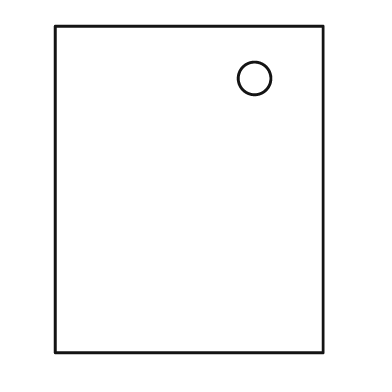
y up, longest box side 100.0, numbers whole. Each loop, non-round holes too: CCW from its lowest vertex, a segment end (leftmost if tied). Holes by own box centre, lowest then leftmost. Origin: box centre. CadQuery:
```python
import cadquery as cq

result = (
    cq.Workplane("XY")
    .moveTo(-41.0, -50.0)
    .lineTo(41.0, -50.0)
    .lineTo(41.0, 50.0)
    .lineTo(-41.0, 50.0)
    .close()
    .moveTo(20.0, 34.0)
    .circle(5.0)
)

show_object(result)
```